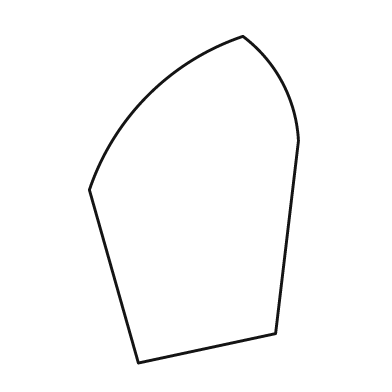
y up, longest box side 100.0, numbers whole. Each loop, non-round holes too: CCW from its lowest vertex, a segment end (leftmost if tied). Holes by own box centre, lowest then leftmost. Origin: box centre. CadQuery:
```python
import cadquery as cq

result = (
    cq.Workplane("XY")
    .moveTo(-17.0, -50.0)
    .lineTo(25.0, -41.0)
    .lineTo(32.0, 18.0)
    .threePointArc((27.0, 36.0), (15.0, 50.0))
    .threePointArc((-14.0, 32.0), (-32.0, 3.0))
    .close()
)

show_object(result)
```